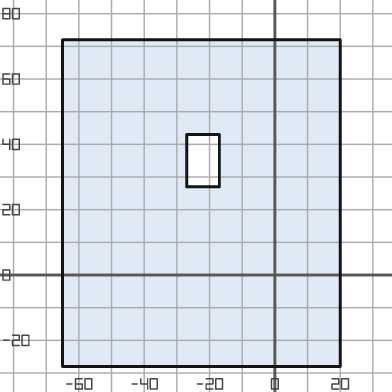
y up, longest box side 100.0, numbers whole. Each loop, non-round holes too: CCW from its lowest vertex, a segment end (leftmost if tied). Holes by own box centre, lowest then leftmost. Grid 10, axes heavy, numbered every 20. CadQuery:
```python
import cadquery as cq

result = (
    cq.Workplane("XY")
    .moveTo(-65.0, -28.0)
    .lineTo(20.0, -28.0)
    .lineTo(20.0, 72.0)
    .lineTo(-65.0, 72.0)
    .close()
    .moveTo(-27.0, 27.0)
    .lineTo(-17.0, 27.0)
    .lineTo(-17.0, 43.0)
    .lineTo(-27.0, 43.0)
    .close()
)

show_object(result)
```